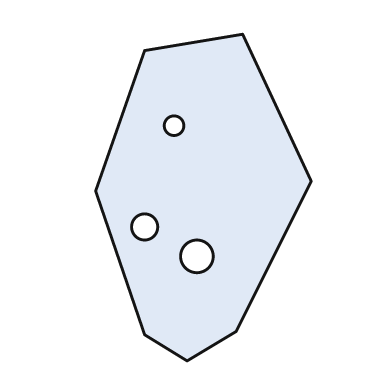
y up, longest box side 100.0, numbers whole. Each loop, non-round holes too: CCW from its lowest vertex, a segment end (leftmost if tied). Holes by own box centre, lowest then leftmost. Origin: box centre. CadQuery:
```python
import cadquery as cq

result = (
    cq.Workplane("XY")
    .moveTo(-5.0, -50.0)
    .lineTo(10.0, -41.0)
    .lineTo(33.0, 5.0)
    .lineTo(12.0, 50.0)
    .lineTo(-18.0, 45.0)
    .lineTo(-33.0, 2.0)
    .lineTo(-18.0, -42.0)
    .close()
    .moveTo(-2.0, -18.0)
    .circle(5.0)
    .moveTo(-18.0, -9.0)
    .circle(4.0)
    .moveTo(-9.0, 22.0)
    .circle(3.0)
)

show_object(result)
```